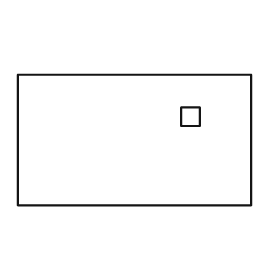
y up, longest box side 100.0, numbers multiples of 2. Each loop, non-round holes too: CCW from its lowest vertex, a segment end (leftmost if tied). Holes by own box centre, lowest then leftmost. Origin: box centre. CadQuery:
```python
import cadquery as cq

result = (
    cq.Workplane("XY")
    .moveTo(-50.0, -28.0)
    .lineTo(50.0, -28.0)
    .lineTo(50.0, 28.0)
    .lineTo(-50.0, 28.0)
    .close()
    .moveTo(20.0, 6.0)
    .lineTo(28.0, 6.0)
    .lineTo(28.0, 14.0)
    .lineTo(20.0, 14.0)
    .close()
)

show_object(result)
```